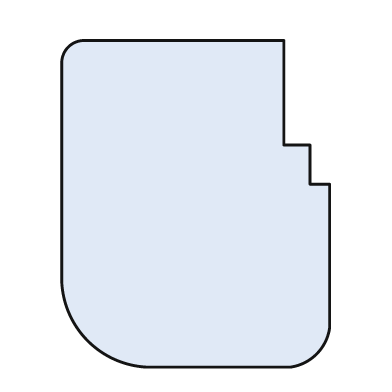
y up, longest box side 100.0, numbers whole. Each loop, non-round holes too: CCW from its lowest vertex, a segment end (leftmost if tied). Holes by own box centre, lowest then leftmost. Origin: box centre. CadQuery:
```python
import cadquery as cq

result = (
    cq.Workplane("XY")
    .moveTo(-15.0, -50.0)
    .lineTo(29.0, -50.0)
    .threePointArc((37.0, -46.0), (41.0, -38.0))
    .lineTo(41.0, 6.0)
    .lineTo(35.0, 6.0)
    .lineTo(35.0, 18.0)
    .lineTo(27.0, 18.0)
    .lineTo(27.0, 50.0)
    .lineTo(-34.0, 50.0)
    .threePointArc((-39.0, 48.0), (-41.0, 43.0))
    .lineTo(-41.0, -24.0)
    .threePointArc((-33.0, -42.0), (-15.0, -50.0))
    .close()
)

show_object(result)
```